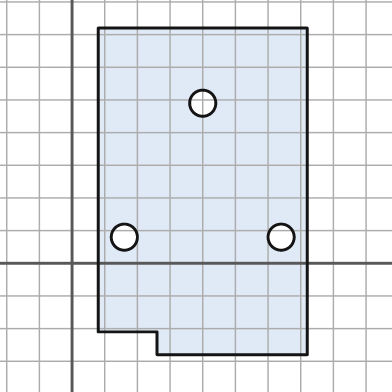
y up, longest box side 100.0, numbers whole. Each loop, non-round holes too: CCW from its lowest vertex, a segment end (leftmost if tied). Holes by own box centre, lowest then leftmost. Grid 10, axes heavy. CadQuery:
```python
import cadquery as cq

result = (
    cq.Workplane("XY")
    .moveTo(26.0, -28.0)
    .lineTo(72.0, -28.0)
    .lineTo(72.0, 72.0)
    .lineTo(8.0, 72.0)
    .lineTo(8.0, -21.0)
    .lineTo(26.0, -21.0)
    .close()
    .moveTo(16.0, 8.0)
    .circle(4.0)
    .moveTo(64.0, 8.0)
    .circle(4.0)
    .moveTo(40.0, 49.0)
    .circle(4.0)
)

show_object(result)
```